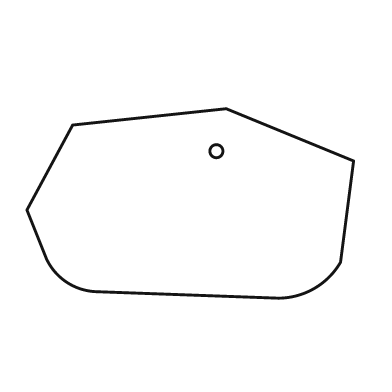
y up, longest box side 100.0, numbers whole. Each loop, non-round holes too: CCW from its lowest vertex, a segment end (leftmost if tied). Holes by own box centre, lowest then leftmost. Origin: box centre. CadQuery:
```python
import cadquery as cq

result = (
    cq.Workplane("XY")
    .moveTo(27.0, -29.0)
    .threePointArc((38.0, -26.0), (46.0, -18.0))
    .lineTo(50.0, 13.0)
    .lineTo(11.0, 29.0)
    .lineTo(-36.0, 24.0)
    .lineTo(-50.0, -2.0)
    .lineTo(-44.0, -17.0)
    .threePointArc((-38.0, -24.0), (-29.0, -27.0))
    .close()
    .moveTo(8.0, 16.0)
    .circle(2.0)
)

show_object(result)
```